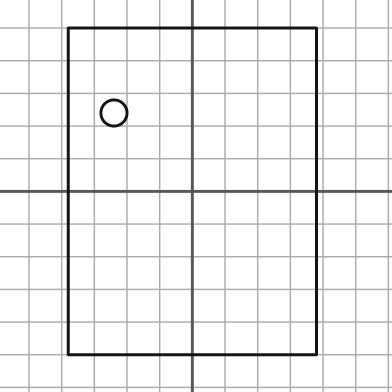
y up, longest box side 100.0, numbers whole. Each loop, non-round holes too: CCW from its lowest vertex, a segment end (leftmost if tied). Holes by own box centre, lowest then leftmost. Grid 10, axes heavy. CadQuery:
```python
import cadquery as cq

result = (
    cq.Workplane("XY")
    .moveTo(-38.0, -50.0)
    .lineTo(38.0, -50.0)
    .lineTo(38.0, 50.0)
    .lineTo(-38.0, 50.0)
    .close()
    .moveTo(-24.0, 24.0)
    .circle(4.0)
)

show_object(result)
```